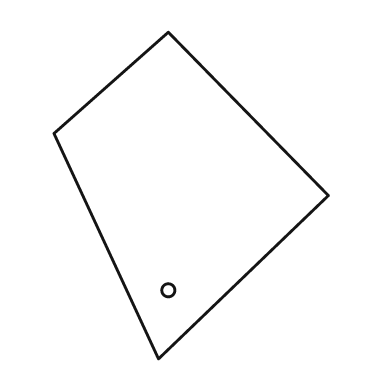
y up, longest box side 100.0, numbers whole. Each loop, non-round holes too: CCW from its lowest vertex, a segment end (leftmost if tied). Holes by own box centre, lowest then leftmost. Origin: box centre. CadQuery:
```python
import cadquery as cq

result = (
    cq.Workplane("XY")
    .moveTo(-10.0, -50.0)
    .lineTo(42.0, 0.0)
    .lineTo(-7.0, 50.0)
    .lineTo(-42.0, 19.0)
    .close()
    .moveTo(-7.0, -29.0)
    .circle(2.0)
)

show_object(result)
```